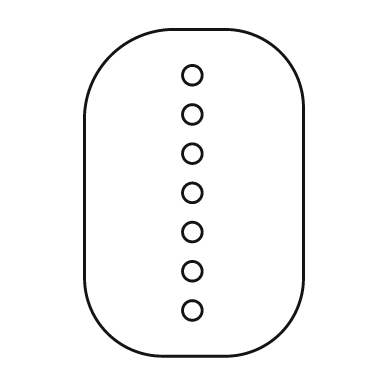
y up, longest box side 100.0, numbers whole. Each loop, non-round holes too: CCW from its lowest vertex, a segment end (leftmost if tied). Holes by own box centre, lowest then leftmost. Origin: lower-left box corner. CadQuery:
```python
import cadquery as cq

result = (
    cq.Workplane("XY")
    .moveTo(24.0, 0.0)
    .lineTo(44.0, 0.0)
    .threePointArc((60.0, 7.0), (67.0, 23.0))
    .lineTo(67.0, 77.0)
    .threePointArc((60.0, 93.0), (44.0, 100.0))
    .lineTo(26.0, 100.0)
    .threePointArc((8.0, 92.0), (0.0, 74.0))
    .lineTo(0.0, 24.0)
    .threePointArc((7.0, 7.0), (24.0, 0.0))
    .close()
    .moveTo(33.0, 14.0)
    .circle(3.0)
    .moveTo(33.0, 26.0)
    .circle(3.0)
    .moveTo(33.0, 38.0)
    .circle(3.0)
    .moveTo(33.0, 50.0)
    .circle(3.0)
    .moveTo(33.0, 62.0)
    .circle(3.0)
    .moveTo(33.0, 74.0)
    .circle(3.0)
    .moveTo(33.0, 86.0)
    .circle(3.0)
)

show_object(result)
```